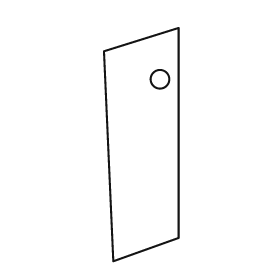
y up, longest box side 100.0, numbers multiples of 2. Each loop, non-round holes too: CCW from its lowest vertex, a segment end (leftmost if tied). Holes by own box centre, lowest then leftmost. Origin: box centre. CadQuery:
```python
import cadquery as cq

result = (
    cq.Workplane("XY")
    .moveTo(-12.0, -50.0)
    .lineTo(16.0, -40.0)
    .lineTo(16.0, 50.0)
    .lineTo(-16.0, 40.0)
    .close()
    .moveTo(8.0, 28.0)
    .circle(4.0)
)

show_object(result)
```